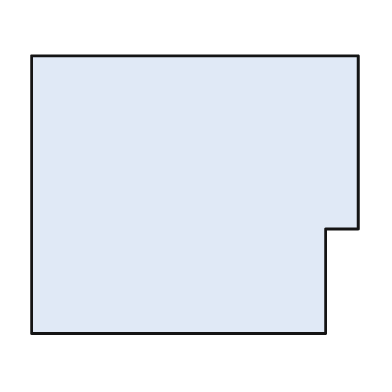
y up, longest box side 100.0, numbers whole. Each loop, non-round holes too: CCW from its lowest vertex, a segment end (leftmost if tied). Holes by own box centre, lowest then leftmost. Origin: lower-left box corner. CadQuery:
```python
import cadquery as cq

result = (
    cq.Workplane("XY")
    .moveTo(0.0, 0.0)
    .lineTo(90.0, 0.0)
    .lineTo(90.0, 32.0)
    .lineTo(100.0, 32.0)
    .lineTo(100.0, 85.0)
    .lineTo(0.0, 85.0)
    .close()
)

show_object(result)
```